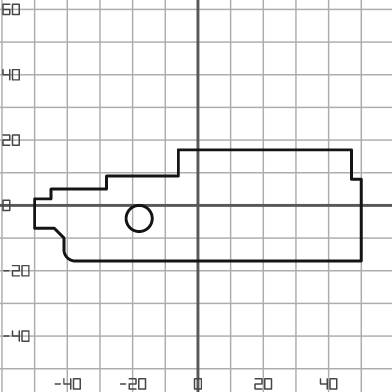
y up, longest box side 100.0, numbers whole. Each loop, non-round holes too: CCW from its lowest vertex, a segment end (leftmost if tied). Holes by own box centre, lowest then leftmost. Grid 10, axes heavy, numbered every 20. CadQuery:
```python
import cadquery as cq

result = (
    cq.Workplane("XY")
    .moveTo(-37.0, -17.0)
    .lineTo(50.0, -17.0)
    .lineTo(50.0, 8.0)
    .lineTo(47.0, 8.0)
    .lineTo(47.0, 17.0)
    .lineTo(-6.0, 17.0)
    .lineTo(-6.0, 9.0)
    .lineTo(-28.0, 9.0)
    .lineTo(-28.0, 5.0)
    .lineTo(-45.0, 5.0)
    .lineTo(-45.0, 2.0)
    .lineTo(-50.0, 2.0)
    .lineTo(-50.0, -7.0)
    .lineTo(-44.0, -7.0)
    .lineTo(-41.0, -10.0)
    .lineTo(-41.0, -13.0)
    .threePointArc((-40.0, -16.0), (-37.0, -17.0))
    .close()
    .moveTo(-18.0, -4.0)
    .circle(4.0)
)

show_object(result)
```